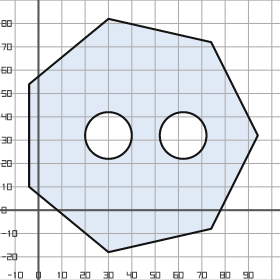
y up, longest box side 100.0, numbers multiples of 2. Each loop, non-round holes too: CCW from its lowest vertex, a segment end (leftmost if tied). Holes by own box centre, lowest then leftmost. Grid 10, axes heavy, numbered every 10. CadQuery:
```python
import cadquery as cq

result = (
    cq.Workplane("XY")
    .moveTo(30.0, -18.0)
    .lineTo(74.0, -8.0)
    .lineTo(94.0, 32.0)
    .lineTo(74.0, 72.0)
    .lineTo(30.0, 82.0)
    .lineTo(-4.0, 54.0)
    .lineTo(-4.0, 10.0)
    .close()
    .moveTo(30.0, 32.0)
    .circle(10.0)
    .moveTo(62.0, 32.0)
    .circle(10.0)
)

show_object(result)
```